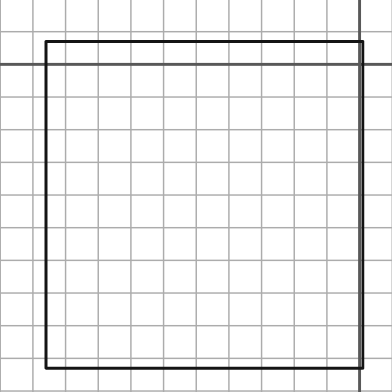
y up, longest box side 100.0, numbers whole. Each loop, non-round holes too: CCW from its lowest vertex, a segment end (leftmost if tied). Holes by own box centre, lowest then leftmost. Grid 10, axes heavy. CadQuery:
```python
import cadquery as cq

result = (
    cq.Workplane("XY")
    .moveTo(-96.0, -93.0)
    .lineTo(1.0, -93.0)
    .lineTo(1.0, 7.0)
    .lineTo(-96.0, 7.0)
    .close()
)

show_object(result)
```